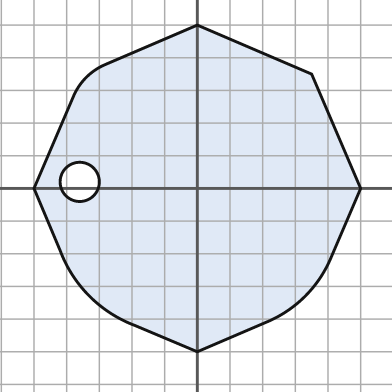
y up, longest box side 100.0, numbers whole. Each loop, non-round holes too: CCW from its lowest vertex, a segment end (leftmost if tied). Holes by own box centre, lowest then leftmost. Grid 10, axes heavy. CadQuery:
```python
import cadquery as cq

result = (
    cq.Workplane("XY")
    .moveTo(0.0, -50.0)
    .lineTo(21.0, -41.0)
    .threePointArc((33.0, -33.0), (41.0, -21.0))
    .lineTo(50.0, 0.0)
    .lineTo(35.0, 35.0)
    .lineTo(0.0, 50.0)
    .lineTo(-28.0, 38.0)
    .threePointArc((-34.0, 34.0), (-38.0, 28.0))
    .lineTo(-50.0, 0.0)
    .lineTo(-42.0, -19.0)
    .threePointArc((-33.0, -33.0), (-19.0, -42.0))
    .close()
    .moveTo(-36.0, 2.0)
    .circle(6.0)
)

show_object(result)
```